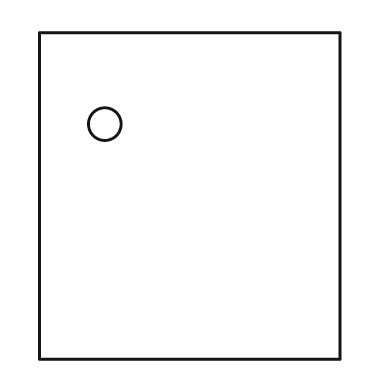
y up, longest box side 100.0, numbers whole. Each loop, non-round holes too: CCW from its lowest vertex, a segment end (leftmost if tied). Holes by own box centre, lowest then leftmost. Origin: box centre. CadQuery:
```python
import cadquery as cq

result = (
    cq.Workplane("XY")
    .moveTo(-46.0, -50.0)
    .lineTo(46.0, -50.0)
    .lineTo(46.0, 50.0)
    .lineTo(-46.0, 50.0)
    .close()
    .moveTo(-26.0, 22.0)
    .circle(5.0)
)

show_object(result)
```